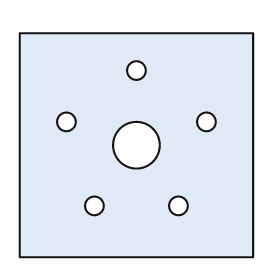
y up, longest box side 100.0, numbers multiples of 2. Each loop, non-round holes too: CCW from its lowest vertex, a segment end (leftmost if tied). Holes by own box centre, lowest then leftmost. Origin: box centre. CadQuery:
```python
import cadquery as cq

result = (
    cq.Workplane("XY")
    .moveTo(-50.0, -48.0)
    .lineTo(50.0, -48.0)
    .lineTo(50.0, 48.0)
    .lineTo(-50.0, 48.0)
    .close()
    .moveTo(-18.0, -26.0)
    .circle(4.0)
    .moveTo(18.0, -26.0)
    .circle(4.0)
    .moveTo(0.0, 0.0)
    .circle(10.0)
    .moveTo(-30.0, 10.0)
    .circle(4.0)
    .moveTo(30.0, 10.0)
    .circle(4.0)
    .moveTo(0.0, 32.0)
    .circle(4.0)
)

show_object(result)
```